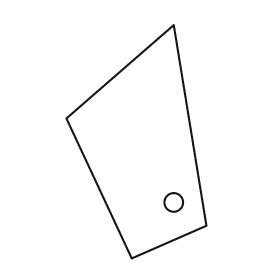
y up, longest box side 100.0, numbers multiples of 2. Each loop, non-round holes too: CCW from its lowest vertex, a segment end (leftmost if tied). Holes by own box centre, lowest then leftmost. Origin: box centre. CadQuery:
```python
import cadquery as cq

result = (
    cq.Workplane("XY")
    .moveTo(-2.0, -50.0)
    .lineTo(30.0, -36.0)
    .lineTo(16.0, 50.0)
    .lineTo(-30.0, 10.0)
    .close()
    .moveTo(16.0, -26.0)
    .circle(4.0)
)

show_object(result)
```